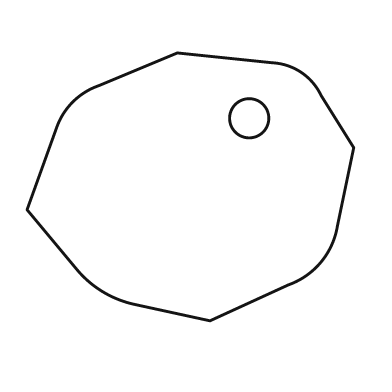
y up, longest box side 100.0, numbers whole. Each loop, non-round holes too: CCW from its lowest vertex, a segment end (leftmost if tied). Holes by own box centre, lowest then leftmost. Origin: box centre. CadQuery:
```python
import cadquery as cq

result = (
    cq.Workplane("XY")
    .moveTo(6.0, -41.0)
    .lineTo(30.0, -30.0)
    .threePointArc((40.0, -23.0), (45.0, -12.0))
    .lineTo(50.0, 12.0)
    .lineTo(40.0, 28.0)
    .threePointArc((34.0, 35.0), (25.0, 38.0))
    .lineTo(-4.0, 41.0)
    .lineTo(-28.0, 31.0)
    .threePointArc((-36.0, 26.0), (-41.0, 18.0))
    .lineTo(-50.0, -7.0)
    .lineTo(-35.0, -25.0)
    .threePointArc((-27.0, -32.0), (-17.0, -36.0))
    .close()
    .moveTo(18.0, 21.0)
    .circle(6.0)
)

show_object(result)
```